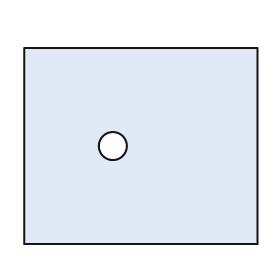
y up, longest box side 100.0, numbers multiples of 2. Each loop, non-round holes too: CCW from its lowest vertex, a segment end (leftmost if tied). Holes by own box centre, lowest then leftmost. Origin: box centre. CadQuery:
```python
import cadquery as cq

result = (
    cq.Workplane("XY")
    .moveTo(-50.0, -42.0)
    .lineTo(50.0, -42.0)
    .lineTo(50.0, 42.0)
    .lineTo(-50.0, 42.0)
    .close()
    .moveTo(-12.0, 0.0)
    .circle(6.0)
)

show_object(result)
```